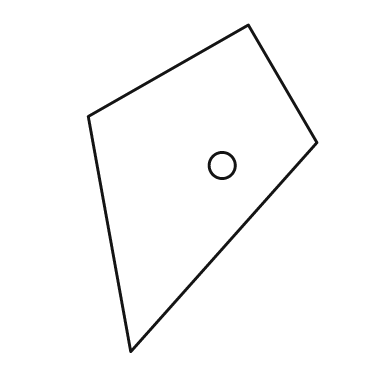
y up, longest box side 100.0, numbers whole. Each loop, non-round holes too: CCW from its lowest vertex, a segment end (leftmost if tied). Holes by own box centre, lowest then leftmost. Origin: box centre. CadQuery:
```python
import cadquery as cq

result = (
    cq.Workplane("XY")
    .moveTo(-22.0, -50.0)
    .lineTo(35.0, 14.0)
    .lineTo(14.0, 50.0)
    .lineTo(-35.0, 22.0)
    .close()
    .moveTo(6.0, 7.0)
    .circle(4.0)
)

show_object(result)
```